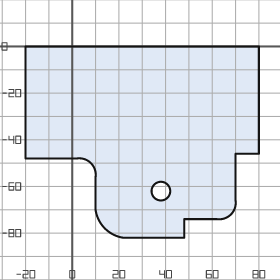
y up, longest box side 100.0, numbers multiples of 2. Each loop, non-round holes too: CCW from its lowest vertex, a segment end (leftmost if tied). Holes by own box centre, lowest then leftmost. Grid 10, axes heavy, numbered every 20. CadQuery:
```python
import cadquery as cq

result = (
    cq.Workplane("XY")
    .moveTo(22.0, -82.0)
    .lineTo(48.0, -82.0)
    .lineTo(48.0, -74.0)
    .lineTo(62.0, -74.0)
    .threePointArc((68.0, -72.0), (70.0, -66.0))
    .lineTo(70.0, -46.0)
    .lineTo(80.0, -46.0)
    .lineTo(80.0, 0.0)
    .lineTo(-20.0, 0.0)
    .lineTo(-20.0, -48.0)
    .lineTo(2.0, -48.0)
    .threePointArc((8.0, -50.0), (10.0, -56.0))
    .lineTo(10.0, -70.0)
    .threePointArc((14.0, -78.0), (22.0, -82.0))
    .close()
    .moveTo(38.0, -62.0)
    .circle(4.0)
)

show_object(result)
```